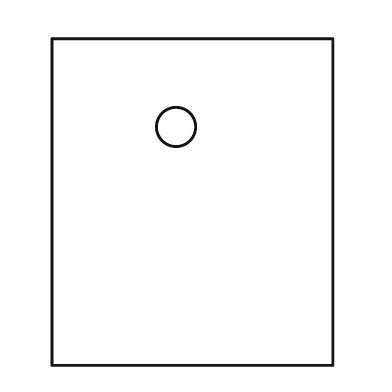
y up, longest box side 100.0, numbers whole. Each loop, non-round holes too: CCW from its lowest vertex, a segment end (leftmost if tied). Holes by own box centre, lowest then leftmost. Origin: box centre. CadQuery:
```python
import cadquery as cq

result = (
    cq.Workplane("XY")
    .moveTo(-43.0, -50.0)
    .lineTo(43.0, -50.0)
    .lineTo(43.0, 50.0)
    .lineTo(-43.0, 50.0)
    .close()
    .moveTo(-5.0, 23.0)
    .circle(6.0)
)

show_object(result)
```